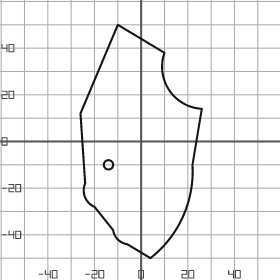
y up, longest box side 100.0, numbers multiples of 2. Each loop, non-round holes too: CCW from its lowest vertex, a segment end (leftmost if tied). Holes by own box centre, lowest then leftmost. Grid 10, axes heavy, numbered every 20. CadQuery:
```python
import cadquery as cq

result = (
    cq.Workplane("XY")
    .moveTo(4.0, -50.0)
    .threePointArc((18.0, -32.0), (22.0, -10.0))
    .lineTo(26.0, 14.0)
    .threePointArc((12.0, 22.0), (10.0, 38.0))
    .lineTo(-10.0, 50.0)
    .lineTo(-26.0, 12.0)
    .lineTo(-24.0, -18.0)
    .threePointArc((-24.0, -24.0), (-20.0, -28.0))
    .lineTo(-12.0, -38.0)
    .threePointArc((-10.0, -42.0), (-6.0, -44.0))
    .close()
    .moveTo(-14.0, -10.0)
    .circle(2.0)
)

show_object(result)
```